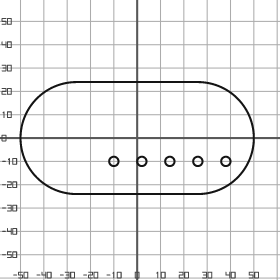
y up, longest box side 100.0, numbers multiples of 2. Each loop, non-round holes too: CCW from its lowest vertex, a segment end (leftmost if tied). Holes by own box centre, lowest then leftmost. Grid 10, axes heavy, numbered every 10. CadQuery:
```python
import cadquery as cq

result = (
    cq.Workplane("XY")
    .moveTo(-26.0, -24.0)
    .lineTo(26.0, -24.0)
    .threePointArc((50.0, 0.0), (26.0, 24.0))
    .lineTo(-26.0, 24.0)
    .threePointArc((-50.0, 0.0), (-26.0, -24.0))
    .close()
    .moveTo(-10.0, -10.0)
    .circle(2.0)
    .moveTo(2.0, -10.0)
    .circle(2.0)
    .moveTo(14.0, -10.0)
    .circle(2.0)
    .moveTo(26.0, -10.0)
    .circle(2.0)
    .moveTo(38.0, -10.0)
    .circle(2.0)
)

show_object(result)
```